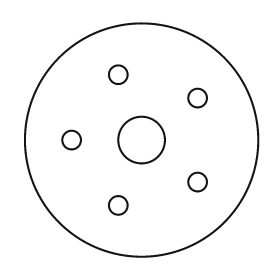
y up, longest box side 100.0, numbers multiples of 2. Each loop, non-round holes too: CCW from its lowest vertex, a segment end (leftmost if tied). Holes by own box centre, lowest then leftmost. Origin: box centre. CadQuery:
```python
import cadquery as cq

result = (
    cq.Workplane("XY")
    .moveTo(0.0, 0.0)
    .circle(50.0)
    .moveTo(-10.0, -28.0)
    .circle(4.0)
    .moveTo(24.0, -18.0)
    .circle(4.0)
    .moveTo(-30.0, 0.0)
    .circle(4.0)
    .moveTo(0.0, 0.0)
    .circle(10.0)
    .moveTo(24.0, 18.0)
    .circle(4.0)
    .moveTo(-10.0, 28.0)
    .circle(4.0)
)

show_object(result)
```